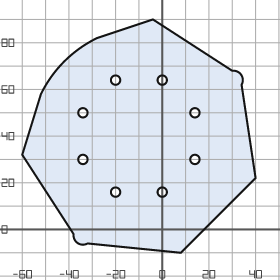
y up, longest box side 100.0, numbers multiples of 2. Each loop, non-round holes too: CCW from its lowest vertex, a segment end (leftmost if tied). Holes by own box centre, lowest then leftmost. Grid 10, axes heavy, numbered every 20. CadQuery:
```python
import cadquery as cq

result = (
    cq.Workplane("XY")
    .moveTo(8.0, -10.0)
    .lineTo(40.0, 22.0)
    .lineTo(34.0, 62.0)
    .threePointArc((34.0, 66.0), (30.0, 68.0))
    .lineTo(-4.0, 90.0)
    .lineTo(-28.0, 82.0)
    .threePointArc((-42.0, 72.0), (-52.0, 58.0))
    .lineTo(-60.0, 32.0)
    .lineTo(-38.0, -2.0)
    .threePointArc((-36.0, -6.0), (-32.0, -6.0))
    .close()
    .moveTo(-20.0, 16.0)
    .circle(2.0)
    .moveTo(0.0, 16.0)
    .circle(2.0)
    .moveTo(-34.0, 30.0)
    .circle(2.0)
    .moveTo(14.0, 30.0)
    .circle(2.0)
    .moveTo(-34.0, 50.0)
    .circle(2.0)
    .moveTo(14.0, 50.0)
    .circle(2.0)
    .moveTo(-20.0, 64.0)
    .circle(2.0)
    .moveTo(0.0, 64.0)
    .circle(2.0)
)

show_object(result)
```